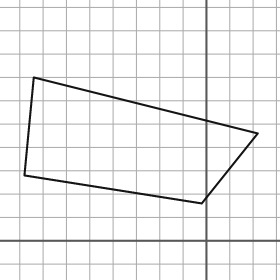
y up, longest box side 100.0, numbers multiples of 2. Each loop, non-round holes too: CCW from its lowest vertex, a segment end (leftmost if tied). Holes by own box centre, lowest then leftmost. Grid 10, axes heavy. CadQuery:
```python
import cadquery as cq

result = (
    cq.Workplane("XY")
    .moveTo(-2.0, 16.0)
    .lineTo(22.0, 46.0)
    .lineTo(-74.0, 70.0)
    .lineTo(-78.0, 28.0)
    .close()
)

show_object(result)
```